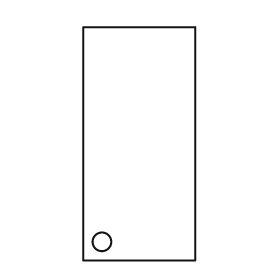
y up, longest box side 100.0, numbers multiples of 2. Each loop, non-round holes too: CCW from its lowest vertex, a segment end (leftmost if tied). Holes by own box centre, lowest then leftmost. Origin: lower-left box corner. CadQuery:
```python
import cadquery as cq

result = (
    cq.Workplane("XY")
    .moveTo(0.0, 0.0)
    .lineTo(48.0, 0.0)
    .lineTo(48.0, 100.0)
    .lineTo(0.0, 100.0)
    .close()
    .moveTo(8.0, 8.0)
    .circle(4.0)
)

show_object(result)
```